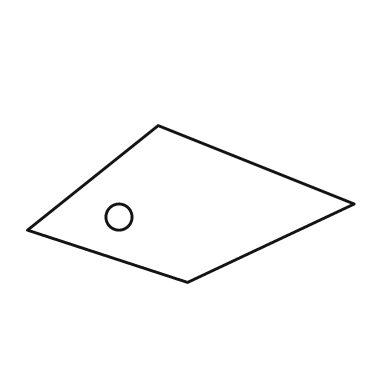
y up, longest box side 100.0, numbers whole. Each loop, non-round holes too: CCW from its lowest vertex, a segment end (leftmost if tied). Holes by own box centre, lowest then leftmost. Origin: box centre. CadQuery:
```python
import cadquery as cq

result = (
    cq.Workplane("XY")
    .moveTo(-1.0, -24.0)
    .lineTo(50.0, 0.0)
    .lineTo(-10.0, 24.0)
    .lineTo(-50.0, -8.0)
    .close()
    .moveTo(-22.0, -4.0)
    .circle(4.0)
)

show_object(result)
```